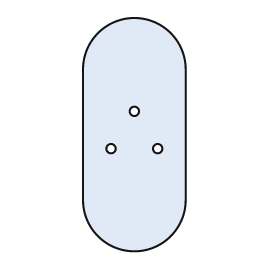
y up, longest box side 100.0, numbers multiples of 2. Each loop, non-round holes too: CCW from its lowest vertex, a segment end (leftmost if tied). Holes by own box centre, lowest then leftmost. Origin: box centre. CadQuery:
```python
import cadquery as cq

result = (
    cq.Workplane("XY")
    .moveTo(-22.0, -28.0)
    .threePointArc((0.0, -50.0), (22.0, -28.0))
    .lineTo(22.0, 28.0)
    .threePointArc((0.0, 50.0), (-22.0, 28.0))
    .close()
    .moveTo(-10.0, -6.0)
    .circle(2.0)
    .moveTo(10.0, -6.0)
    .circle(2.0)
    .moveTo(0.0, 10.0)
    .circle(2.0)
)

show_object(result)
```